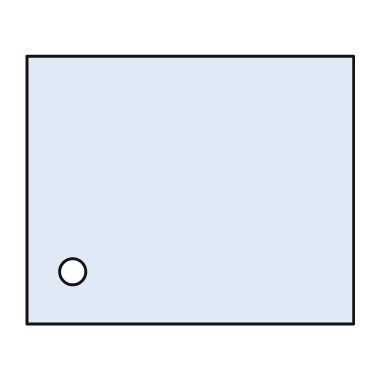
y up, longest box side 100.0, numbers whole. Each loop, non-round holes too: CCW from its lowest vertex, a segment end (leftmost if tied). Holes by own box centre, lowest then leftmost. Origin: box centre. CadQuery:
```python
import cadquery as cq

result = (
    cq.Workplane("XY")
    .moveTo(-50.0, -41.0)
    .lineTo(50.0, -41.0)
    .lineTo(50.0, 41.0)
    .lineTo(-50.0, 41.0)
    .close()
    .moveTo(-36.0, -25.0)
    .circle(4.0)
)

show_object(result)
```